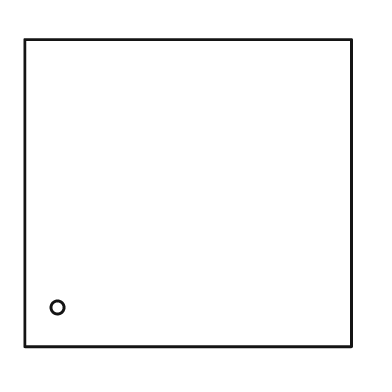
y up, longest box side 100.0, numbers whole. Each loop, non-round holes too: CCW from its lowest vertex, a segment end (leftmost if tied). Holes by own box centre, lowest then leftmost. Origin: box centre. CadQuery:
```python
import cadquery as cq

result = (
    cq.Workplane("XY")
    .moveTo(-50.0, -47.0)
    .lineTo(50.0, -47.0)
    .lineTo(50.0, 47.0)
    .lineTo(-50.0, 47.0)
    .close()
    .moveTo(-40.0, -35.0)
    .circle(2.0)
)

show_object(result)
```